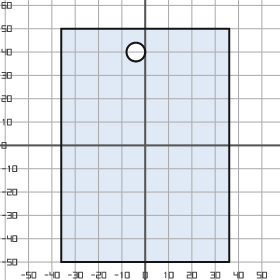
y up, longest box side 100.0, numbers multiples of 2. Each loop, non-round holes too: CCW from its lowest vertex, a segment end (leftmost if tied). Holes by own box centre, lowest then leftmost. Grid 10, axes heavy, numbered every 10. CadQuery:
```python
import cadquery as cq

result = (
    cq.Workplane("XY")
    .moveTo(-36.0, -50.0)
    .lineTo(36.0, -50.0)
    .lineTo(36.0, 50.0)
    .lineTo(-36.0, 50.0)
    .close()
    .moveTo(-4.0, 40.0)
    .circle(4.0)
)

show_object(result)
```